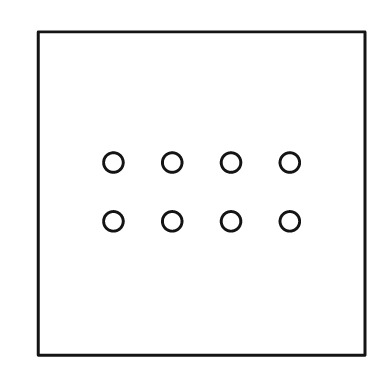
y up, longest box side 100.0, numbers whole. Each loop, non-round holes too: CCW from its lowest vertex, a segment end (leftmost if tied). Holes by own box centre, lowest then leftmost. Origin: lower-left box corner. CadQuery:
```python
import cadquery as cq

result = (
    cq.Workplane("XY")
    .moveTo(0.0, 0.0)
    .lineTo(100.0, 0.0)
    .lineTo(100.0, 99.0)
    .lineTo(0.0, 99.0)
    .close()
    .moveTo(23.0, 41.0)
    .circle(3.0)
    .moveTo(41.0, 41.0)
    .circle(3.0)
    .moveTo(59.0, 41.0)
    .circle(3.0)
    .moveTo(77.0, 41.0)
    .circle(3.0)
    .moveTo(23.0, 59.0)
    .circle(3.0)
    .moveTo(41.0, 59.0)
    .circle(3.0)
    .moveTo(59.0, 59.0)
    .circle(3.0)
    .moveTo(77.0, 59.0)
    .circle(3.0)
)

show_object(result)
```